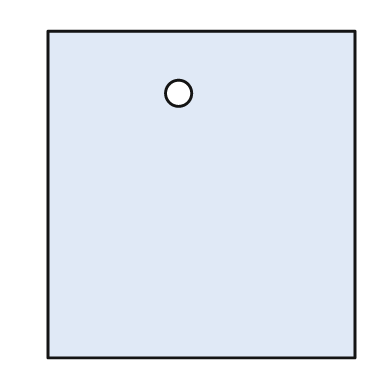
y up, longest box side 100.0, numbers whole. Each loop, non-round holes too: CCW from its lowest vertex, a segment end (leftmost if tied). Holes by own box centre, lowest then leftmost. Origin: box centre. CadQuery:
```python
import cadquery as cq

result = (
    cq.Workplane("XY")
    .moveTo(-47.0, -50.0)
    .lineTo(47.0, -50.0)
    .lineTo(47.0, 50.0)
    .lineTo(-47.0, 50.0)
    .close()
    .moveTo(-7.0, 31.0)
    .circle(4.0)
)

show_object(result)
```